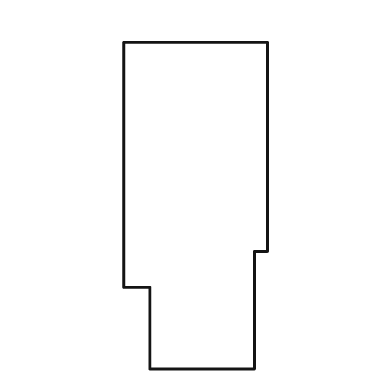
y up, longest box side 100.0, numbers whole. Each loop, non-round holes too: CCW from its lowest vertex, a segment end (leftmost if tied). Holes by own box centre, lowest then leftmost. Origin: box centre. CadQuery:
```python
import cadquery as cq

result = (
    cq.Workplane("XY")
    .moveTo(-14.0, -50.0)
    .lineTo(18.0, -50.0)
    .lineTo(18.0, -14.0)
    .lineTo(22.0, -14.0)
    .lineTo(22.0, 50.0)
    .lineTo(-22.0, 50.0)
    .lineTo(-22.0, -25.0)
    .lineTo(-14.0, -25.0)
    .close()
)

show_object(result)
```